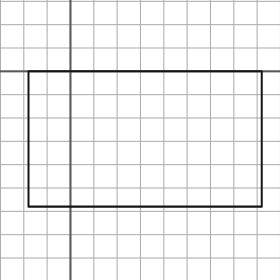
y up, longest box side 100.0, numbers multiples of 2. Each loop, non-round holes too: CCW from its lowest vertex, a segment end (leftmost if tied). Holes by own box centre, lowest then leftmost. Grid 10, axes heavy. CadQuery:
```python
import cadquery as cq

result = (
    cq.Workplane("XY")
    .moveTo(-18.0, -58.0)
    .lineTo(82.0, -58.0)
    .lineTo(82.0, 0.0)
    .lineTo(-18.0, 0.0)
    .close()
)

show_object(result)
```